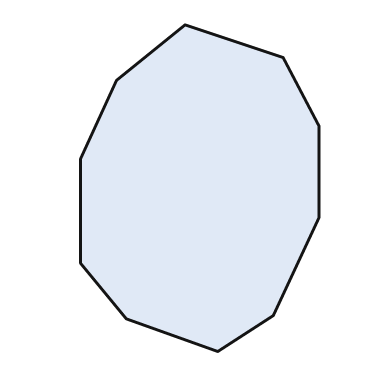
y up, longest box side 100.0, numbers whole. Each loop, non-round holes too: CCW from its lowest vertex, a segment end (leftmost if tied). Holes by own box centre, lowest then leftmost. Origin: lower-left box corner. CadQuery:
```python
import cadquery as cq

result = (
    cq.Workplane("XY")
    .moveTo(42.0, 0.0)
    .lineTo(59.0, 11.0)
    .lineTo(73.0, 41.0)
    .lineTo(73.0, 69.0)
    .lineTo(62.0, 90.0)
    .lineTo(32.0, 100.0)
    .lineTo(11.0, 83.0)
    .lineTo(0.0, 59.0)
    .lineTo(0.0, 27.0)
    .lineTo(14.0, 10.0)
    .close()
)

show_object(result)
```